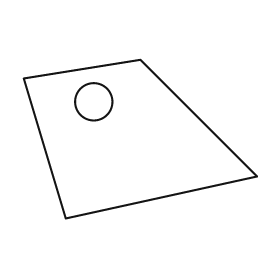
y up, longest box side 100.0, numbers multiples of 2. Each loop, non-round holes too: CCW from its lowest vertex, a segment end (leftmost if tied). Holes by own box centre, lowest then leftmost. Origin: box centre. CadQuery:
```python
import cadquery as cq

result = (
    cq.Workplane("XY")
    .moveTo(-32.0, -34.0)
    .lineTo(50.0, -16.0)
    .lineTo(0.0, 34.0)
    .lineTo(-50.0, 26.0)
    .close()
    .moveTo(-20.0, 16.0)
    .circle(8.0)
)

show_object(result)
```